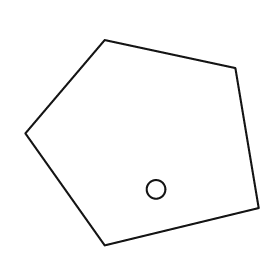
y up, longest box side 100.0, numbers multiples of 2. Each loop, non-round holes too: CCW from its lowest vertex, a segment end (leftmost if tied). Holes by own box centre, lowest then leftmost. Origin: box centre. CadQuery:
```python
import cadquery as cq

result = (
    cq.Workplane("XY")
    .moveTo(-16.0, -44.0)
    .lineTo(50.0, -28.0)
    .lineTo(40.0, 32.0)
    .lineTo(-16.0, 44.0)
    .lineTo(-50.0, 4.0)
    .close()
    .moveTo(6.0, -20.0)
    .circle(4.0)
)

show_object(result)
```